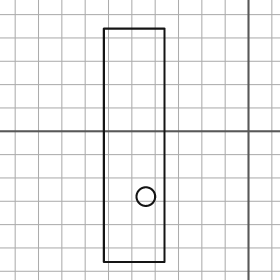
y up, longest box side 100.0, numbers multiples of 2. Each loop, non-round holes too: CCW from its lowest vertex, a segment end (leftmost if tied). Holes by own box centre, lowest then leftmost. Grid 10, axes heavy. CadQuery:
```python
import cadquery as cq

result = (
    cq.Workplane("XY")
    .moveTo(-62.0, -56.0)
    .lineTo(-36.0, -56.0)
    .lineTo(-36.0, 44.0)
    .lineTo(-62.0, 44.0)
    .close()
    .moveTo(-44.0, -28.0)
    .circle(4.0)
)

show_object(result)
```